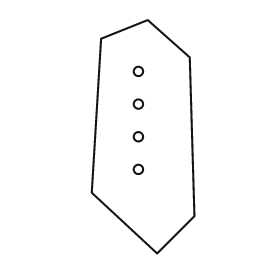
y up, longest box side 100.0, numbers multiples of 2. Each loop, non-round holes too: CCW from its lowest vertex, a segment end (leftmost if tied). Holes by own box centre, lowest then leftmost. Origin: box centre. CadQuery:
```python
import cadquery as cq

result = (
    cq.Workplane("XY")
    .moveTo(6.0, -50.0)
    .lineTo(22.0, -34.0)
    .lineTo(20.0, 34.0)
    .lineTo(2.0, 50.0)
    .lineTo(-18.0, 42.0)
    .lineTo(-22.0, -24.0)
    .close()
    .moveTo(-2.0, -14.0)
    .circle(2.0)
    .moveTo(-2.0, 0.0)
    .circle(2.0)
    .moveTo(-2.0, 14.0)
    .circle(2.0)
    .moveTo(-2.0, 28.0)
    .circle(2.0)
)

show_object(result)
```